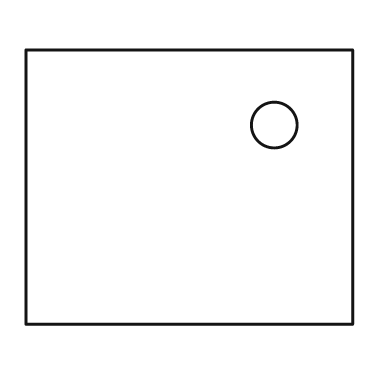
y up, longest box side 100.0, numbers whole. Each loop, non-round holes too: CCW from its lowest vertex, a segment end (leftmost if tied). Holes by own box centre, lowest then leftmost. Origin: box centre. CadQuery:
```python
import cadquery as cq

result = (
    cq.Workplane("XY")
    .moveTo(-50.0, -42.0)
    .lineTo(50.0, -42.0)
    .lineTo(50.0, 42.0)
    .lineTo(-50.0, 42.0)
    .close()
    .moveTo(26.0, 19.0)
    .circle(7.0)
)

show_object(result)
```